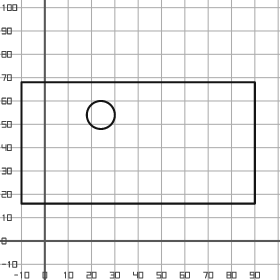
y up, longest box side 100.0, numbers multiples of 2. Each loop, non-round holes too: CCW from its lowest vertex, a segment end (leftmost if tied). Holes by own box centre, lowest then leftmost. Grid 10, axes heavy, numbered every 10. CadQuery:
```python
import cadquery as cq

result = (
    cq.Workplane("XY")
    .moveTo(-10.0, 16.0)
    .lineTo(90.0, 16.0)
    .lineTo(90.0, 68.0)
    .lineTo(-10.0, 68.0)
    .close()
    .moveTo(24.0, 54.0)
    .circle(6.0)
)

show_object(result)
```